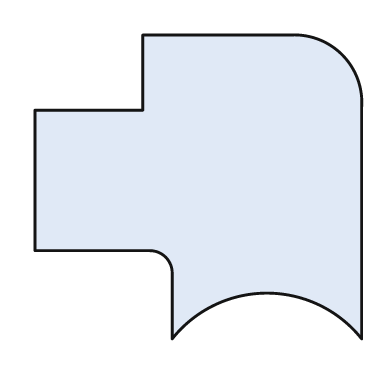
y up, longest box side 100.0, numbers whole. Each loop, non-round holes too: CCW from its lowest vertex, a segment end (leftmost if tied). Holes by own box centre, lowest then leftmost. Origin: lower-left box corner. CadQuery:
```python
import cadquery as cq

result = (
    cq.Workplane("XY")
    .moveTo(42.0, 0.0)
    .threePointArc((71.0, 14.0), (100.0, 0.0))
    .lineTo(100.0, 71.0)
    .threePointArc((94.0, 87.0), (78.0, 93.0))
    .lineTo(33.0, 93.0)
    .lineTo(33.0, 70.0)
    .lineTo(0.0, 70.0)
    .lineTo(0.0, 27.0)
    .lineTo(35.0, 27.0)
    .threePointArc((40.0, 25.0), (42.0, 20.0))
    .close()
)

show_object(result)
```